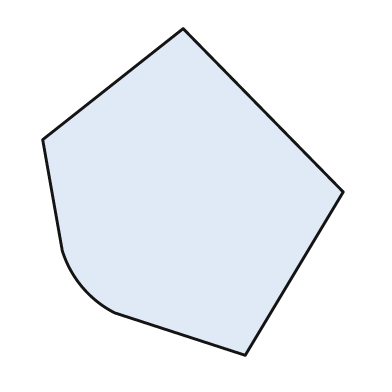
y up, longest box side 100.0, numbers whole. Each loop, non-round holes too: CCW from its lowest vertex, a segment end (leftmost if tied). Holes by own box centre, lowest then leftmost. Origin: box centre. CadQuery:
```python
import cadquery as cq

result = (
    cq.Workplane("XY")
    .moveTo(16.0, -50.0)
    .lineTo(46.0, 0.0)
    .lineTo(-3.0, 50.0)
    .lineTo(-46.0, 16.0)
    .lineTo(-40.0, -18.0)
    .threePointArc((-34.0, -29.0), (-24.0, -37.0))
    .close()
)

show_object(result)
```